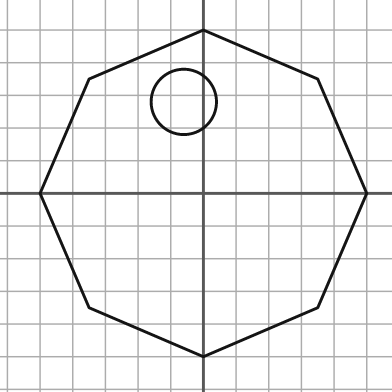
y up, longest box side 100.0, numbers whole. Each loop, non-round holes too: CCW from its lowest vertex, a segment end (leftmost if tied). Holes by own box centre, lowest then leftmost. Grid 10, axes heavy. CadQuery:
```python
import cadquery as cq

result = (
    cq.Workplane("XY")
    .moveTo(0.0, -50.0)
    .lineTo(35.0, -35.0)
    .lineTo(50.0, 0.0)
    .lineTo(35.0, 35.0)
    .lineTo(0.0, 50.0)
    .lineTo(-35.0, 35.0)
    .lineTo(-50.0, 0.0)
    .lineTo(-35.0, -35.0)
    .close()
    .moveTo(-6.0, 28.0)
    .circle(10.0)
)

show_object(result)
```